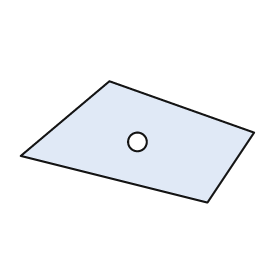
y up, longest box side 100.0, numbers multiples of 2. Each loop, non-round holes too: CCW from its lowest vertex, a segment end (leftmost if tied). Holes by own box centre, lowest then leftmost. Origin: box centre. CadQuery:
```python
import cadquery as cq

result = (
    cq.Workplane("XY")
    .moveTo(30.0, -26.0)
    .lineTo(50.0, 4.0)
    .lineTo(-12.0, 26.0)
    .lineTo(-50.0, -6.0)
    .close()
    .moveTo(0.0, 0.0)
    .circle(4.0)
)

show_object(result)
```